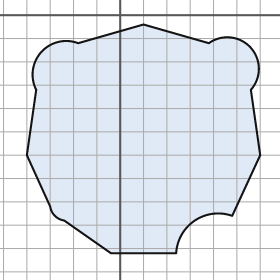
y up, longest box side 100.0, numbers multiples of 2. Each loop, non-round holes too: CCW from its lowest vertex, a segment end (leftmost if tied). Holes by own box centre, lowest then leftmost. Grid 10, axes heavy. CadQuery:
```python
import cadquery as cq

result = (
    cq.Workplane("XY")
    .moveTo(-4.0, -102.0)
    .lineTo(24.0, -102.0)
    .threePointArc((32.0, -88.0), (48.0, -86.0))
    .lineTo(60.0, -60.0)
    .lineTo(56.0, -32.0)
    .threePointArc((56.0, -14.0), (38.0, -12.0))
    .lineTo(10.0, -4.0)
    .lineTo(-18.0, -12.0)
    .threePointArc((-34.0, -16.0), (-36.0, -32.0))
    .lineTo(-40.0, -60.0)
    .lineTo(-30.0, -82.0)
    .threePointArc((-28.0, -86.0), (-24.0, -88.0))
    .close()
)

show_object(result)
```